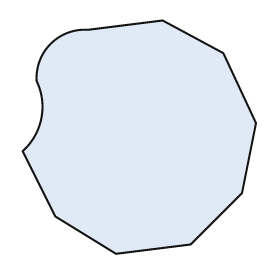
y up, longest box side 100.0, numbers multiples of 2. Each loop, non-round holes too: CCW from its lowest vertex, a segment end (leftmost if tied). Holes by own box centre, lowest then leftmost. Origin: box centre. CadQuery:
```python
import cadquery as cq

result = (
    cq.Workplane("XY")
    .moveTo(-10.0, -50.0)
    .lineTo(22.0, -46.0)
    .lineTo(44.0, -24.0)
    .lineTo(50.0, 6.0)
    .lineTo(36.0, 36.0)
    .lineTo(10.0, 50.0)
    .lineTo(-22.0, 46.0)
    .threePointArc((-38.0, 40.0), (-44.0, 24.0))
    .threePointArc((-42.0, 8.0), (-50.0, -6.0))
    .lineTo(-36.0, -34.0)
    .close()
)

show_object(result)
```